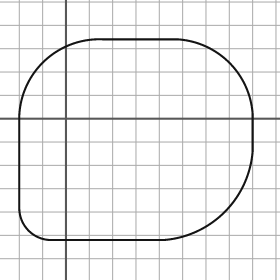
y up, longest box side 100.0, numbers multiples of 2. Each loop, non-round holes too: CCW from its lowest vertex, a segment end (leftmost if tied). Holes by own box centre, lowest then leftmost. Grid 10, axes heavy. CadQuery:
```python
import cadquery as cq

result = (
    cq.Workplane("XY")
    .moveTo(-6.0, -52.0)
    .lineTo(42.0, -52.0)
    .threePointArc((68.0, -40.0), (80.0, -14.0))
    .lineTo(80.0, 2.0)
    .threePointArc((70.0, 24.0), (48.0, 34.0))
    .lineTo(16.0, 34.0)
    .threePointArc((-10.0, 24.0), (-20.0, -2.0))
    .lineTo(-20.0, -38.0)
    .threePointArc((-16.0, -48.0), (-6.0, -52.0))
    .close()
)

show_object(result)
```